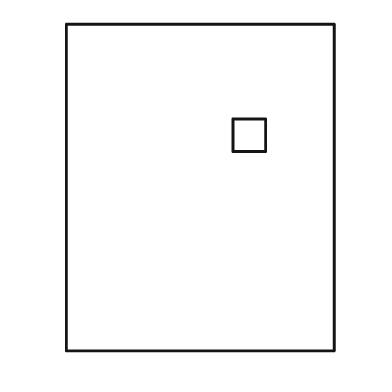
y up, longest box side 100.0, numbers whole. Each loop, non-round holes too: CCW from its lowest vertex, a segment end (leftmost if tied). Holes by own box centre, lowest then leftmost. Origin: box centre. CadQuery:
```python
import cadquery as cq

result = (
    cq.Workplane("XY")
    .moveTo(-41.0, -50.0)
    .lineTo(41.0, -50.0)
    .lineTo(41.0, 50.0)
    .lineTo(-41.0, 50.0)
    .close()
    .moveTo(10.0, 11.0)
    .lineTo(20.0, 11.0)
    .lineTo(20.0, 21.0)
    .lineTo(10.0, 21.0)
    .close()
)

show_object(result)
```